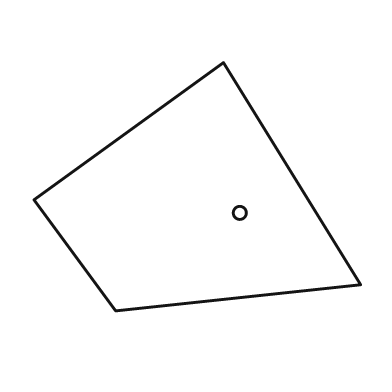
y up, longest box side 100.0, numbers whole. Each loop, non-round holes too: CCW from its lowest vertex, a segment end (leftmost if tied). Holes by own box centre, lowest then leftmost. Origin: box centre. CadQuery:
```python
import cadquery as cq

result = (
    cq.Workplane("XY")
    .moveTo(-25.0, -38.0)
    .lineTo(50.0, -30.0)
    .lineTo(8.0, 38.0)
    .lineTo(-50.0, -4.0)
    .close()
    .moveTo(13.0, -8.0)
    .circle(2.0)
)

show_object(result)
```